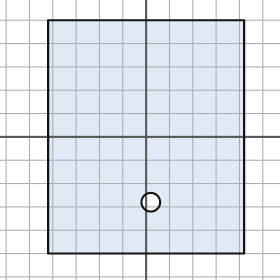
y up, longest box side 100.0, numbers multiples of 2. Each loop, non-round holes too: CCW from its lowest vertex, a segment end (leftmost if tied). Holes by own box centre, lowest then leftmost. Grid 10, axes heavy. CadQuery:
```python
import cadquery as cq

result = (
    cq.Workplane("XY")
    .moveTo(-42.0, -50.0)
    .lineTo(42.0, -50.0)
    .lineTo(42.0, 50.0)
    .lineTo(-42.0, 50.0)
    .close()
    .moveTo(2.0, -28.0)
    .circle(4.0)
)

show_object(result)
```